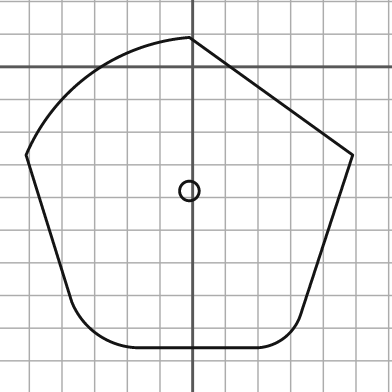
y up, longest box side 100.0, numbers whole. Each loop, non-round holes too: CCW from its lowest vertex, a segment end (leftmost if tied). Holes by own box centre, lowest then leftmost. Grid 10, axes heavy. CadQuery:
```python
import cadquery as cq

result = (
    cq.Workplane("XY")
    .moveTo(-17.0, -86.0)
    .lineTo(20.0, -86.0)
    .threePointArc((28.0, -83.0), (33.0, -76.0))
    .lineTo(49.0, -27.0)
    .lineTo(-1.0, 9.0)
    .threePointArc((-31.0, -2.0), (-51.0, -27.0))
    .lineTo(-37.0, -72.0)
    .threePointArc((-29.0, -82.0), (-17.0, -86.0))
    .close()
    .moveTo(-1.0, -38.0)
    .circle(3.0)
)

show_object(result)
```